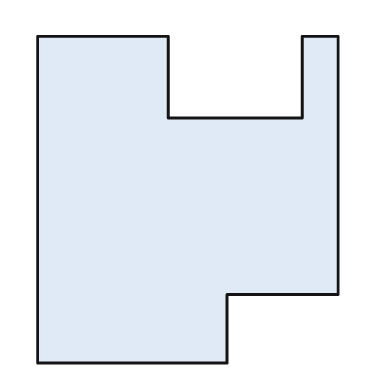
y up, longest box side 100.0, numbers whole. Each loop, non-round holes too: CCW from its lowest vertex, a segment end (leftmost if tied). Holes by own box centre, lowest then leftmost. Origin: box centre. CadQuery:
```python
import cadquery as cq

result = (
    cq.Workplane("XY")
    .moveTo(-46.0, -50.0)
    .lineTo(12.0, -50.0)
    .lineTo(12.0, -29.0)
    .lineTo(46.0, -29.0)
    .lineTo(46.0, 50.0)
    .lineTo(35.0, 50.0)
    .lineTo(35.0, 25.0)
    .lineTo(-6.0, 25.0)
    .lineTo(-6.0, 50.0)
    .lineTo(-46.0, 50.0)
    .close()
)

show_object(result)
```